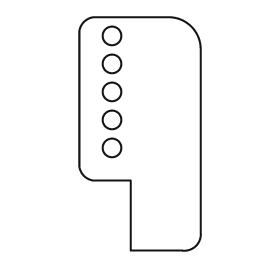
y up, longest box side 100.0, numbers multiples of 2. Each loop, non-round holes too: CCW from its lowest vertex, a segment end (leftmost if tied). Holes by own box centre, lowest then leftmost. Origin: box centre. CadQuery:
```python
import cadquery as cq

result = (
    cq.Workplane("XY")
    .moveTo(-4.0, -50.0)
    .lineTo(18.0, -50.0)
    .threePointArc((24.0, -48.0), (26.0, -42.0))
    .lineTo(26.0, 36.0)
    .threePointArc((22.0, 46.0), (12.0, 50.0))
    .lineTo(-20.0, 50.0)
    .threePointArc((-24.0, 48.0), (-26.0, 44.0))
    .lineTo(-26.0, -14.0)
    .threePointArc((-24.0, -18.0), (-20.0, -20.0))
    .lineTo(-4.0, -20.0)
    .close()
    .moveTo(-12.0, -6.0)
    .circle(4.0)
    .moveTo(-12.0, 6.0)
    .circle(4.0)
    .moveTo(-12.0, 18.0)
    .circle(4.0)
    .moveTo(-12.0, 30.0)
    .circle(4.0)
    .moveTo(-12.0, 42.0)
    .circle(4.0)
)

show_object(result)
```